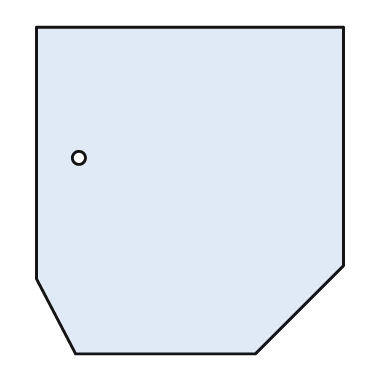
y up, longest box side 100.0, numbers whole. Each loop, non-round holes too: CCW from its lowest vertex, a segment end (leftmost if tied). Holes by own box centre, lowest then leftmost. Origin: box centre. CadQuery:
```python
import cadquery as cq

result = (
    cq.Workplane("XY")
    .moveTo(-35.0, -50.0)
    .lineTo(20.0, -50.0)
    .lineTo(47.0, -23.0)
    .lineTo(47.0, 50.0)
    .lineTo(-47.0, 50.0)
    .lineTo(-47.0, -27.0)
    .close()
    .moveTo(-34.0, 10.0)
    .circle(2.0)
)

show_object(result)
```